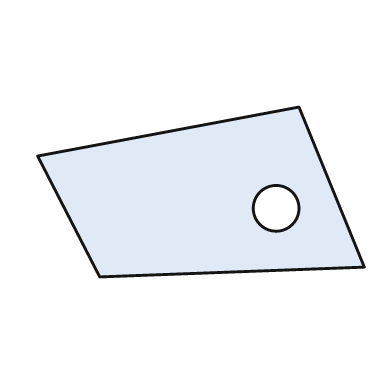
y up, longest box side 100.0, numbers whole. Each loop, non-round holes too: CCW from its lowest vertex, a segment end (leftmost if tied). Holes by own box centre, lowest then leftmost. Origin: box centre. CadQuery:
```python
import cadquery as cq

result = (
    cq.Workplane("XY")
    .moveTo(-31.0, -26.0)
    .lineTo(50.0, -23.0)
    .lineTo(30.0, 26.0)
    .lineTo(-50.0, 11.0)
    .close()
    .moveTo(23.0, -5.0)
    .circle(7.0)
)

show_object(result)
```